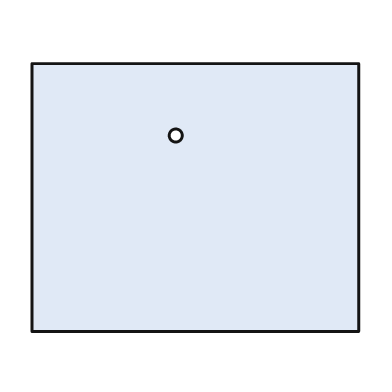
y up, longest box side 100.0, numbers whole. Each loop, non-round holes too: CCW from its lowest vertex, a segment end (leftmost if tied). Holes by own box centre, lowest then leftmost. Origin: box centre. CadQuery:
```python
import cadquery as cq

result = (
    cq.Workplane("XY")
    .moveTo(-50.0, -41.0)
    .lineTo(50.0, -41.0)
    .lineTo(50.0, 41.0)
    .lineTo(-50.0, 41.0)
    .close()
    .moveTo(-6.0, 19.0)
    .circle(2.0)
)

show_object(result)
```